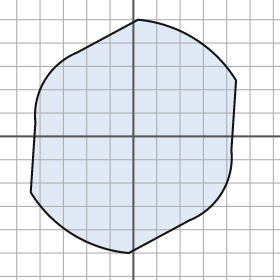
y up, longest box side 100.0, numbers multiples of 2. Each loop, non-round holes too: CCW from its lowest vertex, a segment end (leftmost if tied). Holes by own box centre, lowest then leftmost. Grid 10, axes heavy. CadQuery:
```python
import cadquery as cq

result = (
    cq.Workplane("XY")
    .moveTo(-2.0, -50.0)
    .lineTo(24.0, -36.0)
    .threePointArc((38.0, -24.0), (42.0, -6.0))
    .lineTo(44.0, 24.0)
    .threePointArc((26.0, 42.0), (2.0, 50.0))
    .lineTo(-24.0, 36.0)
    .threePointArc((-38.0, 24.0), (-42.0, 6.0))
    .lineTo(-44.0, -24.0)
    .threePointArc((-26.0, -42.0), (-2.0, -50.0))
    .close()
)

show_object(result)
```